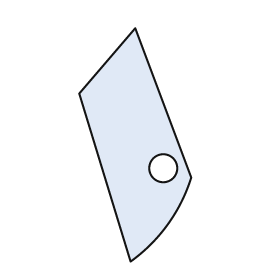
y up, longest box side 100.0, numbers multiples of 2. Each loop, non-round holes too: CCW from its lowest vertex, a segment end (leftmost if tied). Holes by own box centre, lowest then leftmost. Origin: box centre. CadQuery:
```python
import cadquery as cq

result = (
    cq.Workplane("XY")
    .moveTo(-2.0, -50.0)
    .threePointArc((14.0, -34.0), (24.0, -14.0))
    .lineTo(0.0, 50.0)
    .lineTo(-24.0, 22.0)
    .close()
    .moveTo(12.0, -10.0)
    .circle(6.0)
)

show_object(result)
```